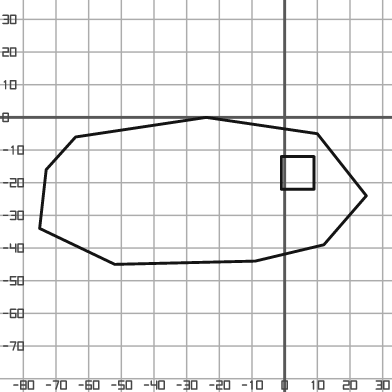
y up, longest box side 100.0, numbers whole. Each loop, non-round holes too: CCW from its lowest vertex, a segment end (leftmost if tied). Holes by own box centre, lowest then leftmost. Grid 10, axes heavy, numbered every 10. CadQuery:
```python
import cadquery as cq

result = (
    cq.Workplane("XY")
    .moveTo(-52.0, -45.0)
    .lineTo(-9.0, -44.0)
    .lineTo(12.0, -39.0)
    .lineTo(25.0, -24.0)
    .lineTo(10.0, -5.0)
    .lineTo(-24.0, 0.0)
    .lineTo(-64.0, -6.0)
    .lineTo(-73.0, -16.0)
    .lineTo(-75.0, -34.0)
    .close()
    .moveTo(-1.0, -22.0)
    .lineTo(9.0, -22.0)
    .lineTo(9.0, -12.0)
    .lineTo(-1.0, -12.0)
    .close()
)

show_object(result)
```